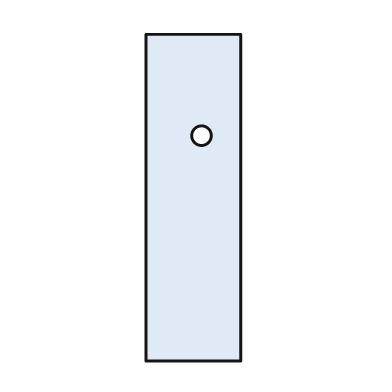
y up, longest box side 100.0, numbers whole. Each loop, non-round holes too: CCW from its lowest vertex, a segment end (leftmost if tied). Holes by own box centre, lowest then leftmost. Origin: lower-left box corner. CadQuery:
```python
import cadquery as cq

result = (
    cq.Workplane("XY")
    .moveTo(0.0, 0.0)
    .lineTo(29.0, 0.0)
    .lineTo(29.0, 100.0)
    .lineTo(0.0, 100.0)
    .close()
    .moveTo(17.0, 69.0)
    .circle(3.0)
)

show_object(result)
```